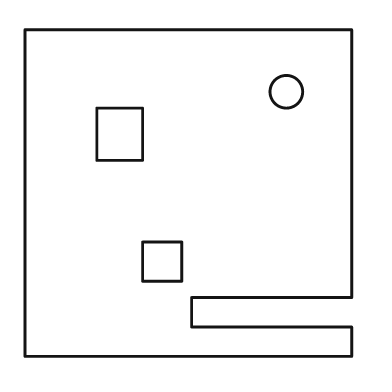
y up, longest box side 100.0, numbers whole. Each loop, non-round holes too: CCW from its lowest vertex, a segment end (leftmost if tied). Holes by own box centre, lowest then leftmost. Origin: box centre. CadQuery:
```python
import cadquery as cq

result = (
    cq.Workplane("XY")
    .moveTo(-50.0, -50.0)
    .lineTo(50.0, -50.0)
    .lineTo(50.0, -41.0)
    .lineTo(1.0, -41.0)
    .lineTo(1.0, -32.0)
    .lineTo(50.0, -32.0)
    .lineTo(50.0, 50.0)
    .lineTo(-50.0, 50.0)
    .close()
    .moveTo(-14.0, -27.0)
    .lineTo(-2.0, -27.0)
    .lineTo(-2.0, -15.0)
    .lineTo(-14.0, -15.0)
    .close()
    .moveTo(-28.0, 10.0)
    .lineTo(-14.0, 10.0)
    .lineTo(-14.0, 26.0)
    .lineTo(-28.0, 26.0)
    .close()
    .moveTo(30.0, 31.0)
    .circle(5.0)
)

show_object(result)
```